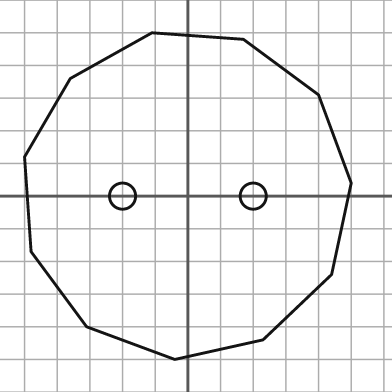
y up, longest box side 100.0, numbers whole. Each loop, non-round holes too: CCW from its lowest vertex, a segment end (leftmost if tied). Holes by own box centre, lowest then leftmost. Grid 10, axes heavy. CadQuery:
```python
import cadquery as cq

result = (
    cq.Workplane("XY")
    .moveTo(-4.0, -50.0)
    .lineTo(23.0, -44.0)
    .lineTo(44.0, -24.0)
    .lineTo(50.0, 4.0)
    .lineTo(40.0, 31.0)
    .lineTo(17.0, 48.0)
    .lineTo(-11.0, 50.0)
    .lineTo(-36.0, 36.0)
    .lineTo(-50.0, 12.0)
    .lineTo(-48.0, -17.0)
    .lineTo(-31.0, -40.0)
    .close()
    .moveTo(-20.0, 0.0)
    .circle(4.0)
    .moveTo(20.0, 0.0)
    .circle(4.0)
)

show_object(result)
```